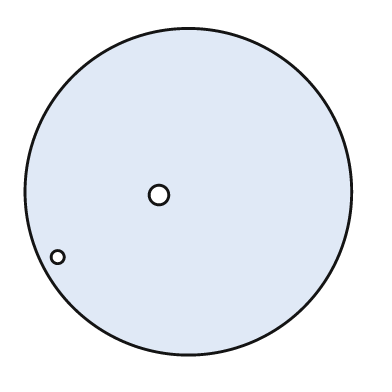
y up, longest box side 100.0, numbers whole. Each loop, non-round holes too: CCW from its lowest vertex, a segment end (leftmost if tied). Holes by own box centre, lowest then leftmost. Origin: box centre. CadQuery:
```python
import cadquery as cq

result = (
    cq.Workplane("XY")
    .moveTo(0.0, 0.0)
    .circle(50.0)
    .moveTo(-40.0, -20.0)
    .circle(2.0)
    .moveTo(-9.0, -1.0)
    .circle(3.0)
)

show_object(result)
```